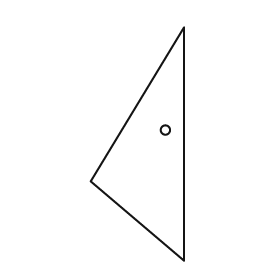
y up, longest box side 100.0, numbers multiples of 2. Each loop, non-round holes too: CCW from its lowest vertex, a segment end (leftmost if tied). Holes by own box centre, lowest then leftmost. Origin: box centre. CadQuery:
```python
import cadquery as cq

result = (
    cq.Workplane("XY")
    .moveTo(20.0, -50.0)
    .lineTo(20.0, 50.0)
    .lineTo(-20.0, -16.0)
    .close()
    .moveTo(12.0, 6.0)
    .circle(2.0)
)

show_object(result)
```